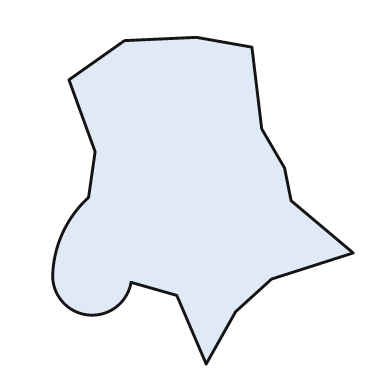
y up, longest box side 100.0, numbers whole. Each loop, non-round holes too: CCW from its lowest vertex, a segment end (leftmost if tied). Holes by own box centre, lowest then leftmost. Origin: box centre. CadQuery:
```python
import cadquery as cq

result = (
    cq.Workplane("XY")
    .moveTo(1.0, -50.0)
    .lineTo(10.0, -34.0)
    .lineTo(21.0, -24.0)
    .lineTo(46.0, -16.0)
    .lineTo(27.0, 0.0)
    .lineTo(25.0, 10.0)
    .lineTo(18.0, 22.0)
    .lineTo(15.0, 47.0)
    .lineTo(-2.0, 50.0)
    .lineTo(-24.0, 49.0)
    .lineTo(-41.0, 37.0)
    .lineTo(-33.0, 15.0)
    .lineTo(-35.0, 1.0)
    .threePointArc((-43.0, -10.0), (-46.0, -23.0))
    .threePointArc((-35.0, -35.0), (-22.0, -25.0))
    .lineTo(-8.0, -29.0)
    .close()
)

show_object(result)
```